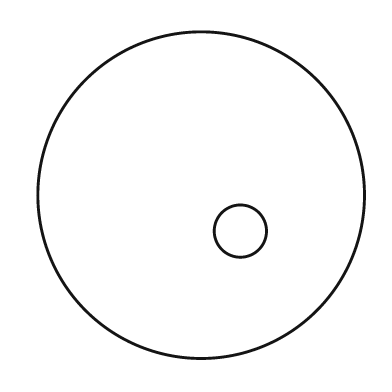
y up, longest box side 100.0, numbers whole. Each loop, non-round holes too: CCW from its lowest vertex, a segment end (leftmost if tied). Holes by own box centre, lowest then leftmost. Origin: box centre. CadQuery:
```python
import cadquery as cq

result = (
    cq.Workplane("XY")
    .moveTo(0.0, 0.0)
    .circle(50.0)
    .moveTo(12.0, -11.0)
    .circle(8.0)
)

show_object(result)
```